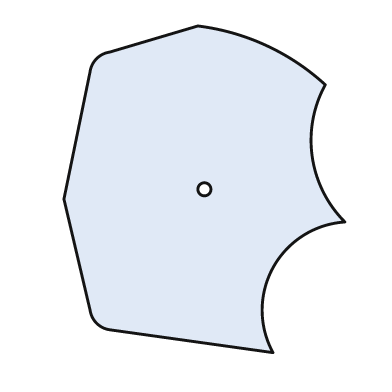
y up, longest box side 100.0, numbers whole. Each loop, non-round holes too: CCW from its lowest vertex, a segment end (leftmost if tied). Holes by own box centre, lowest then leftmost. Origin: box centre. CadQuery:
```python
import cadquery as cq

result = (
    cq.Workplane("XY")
    .moveTo(21.0, -50.0)
    .threePointArc((21.0, -24.0), (43.0, -10.0))
    .threePointArc((33.0, 10.0), (37.0, 32.0))
    .threePointArc((19.0, 44.0), (-2.0, 50.0))
    .lineTo(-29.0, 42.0)
    .threePointArc((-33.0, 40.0), (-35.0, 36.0))
    .lineTo(-43.0, -3.0)
    .lineTo(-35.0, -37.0)
    .threePointArc((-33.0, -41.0), (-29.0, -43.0))
    .close()
    .moveTo(0.0, 0.0)
    .circle(2.0)
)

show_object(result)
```